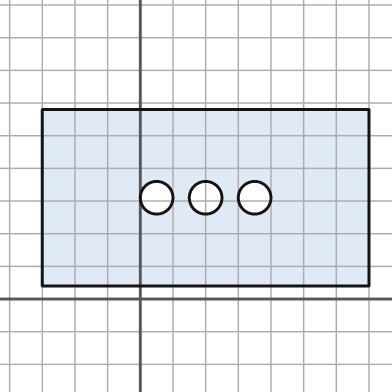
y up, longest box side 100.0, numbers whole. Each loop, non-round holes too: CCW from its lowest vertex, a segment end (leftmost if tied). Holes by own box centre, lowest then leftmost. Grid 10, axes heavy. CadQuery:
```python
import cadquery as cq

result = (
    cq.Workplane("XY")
    .moveTo(-30.0, 4.0)
    .lineTo(70.0, 4.0)
    .lineTo(70.0, 58.0)
    .lineTo(-30.0, 58.0)
    .close()
    .moveTo(5.0, 31.0)
    .circle(5.0)
    .moveTo(20.0, 31.0)
    .circle(5.0)
    .moveTo(35.0, 31.0)
    .circle(5.0)
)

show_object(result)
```